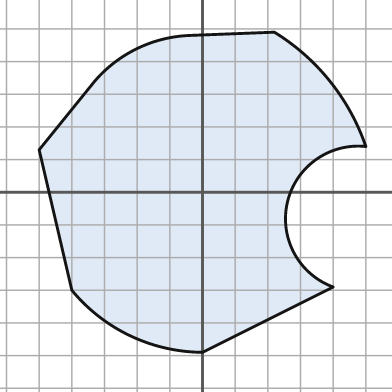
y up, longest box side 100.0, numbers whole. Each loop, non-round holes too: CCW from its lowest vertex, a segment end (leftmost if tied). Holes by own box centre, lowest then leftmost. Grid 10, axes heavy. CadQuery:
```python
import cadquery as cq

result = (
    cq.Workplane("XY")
    .moveTo(0.0, -49.0)
    .lineTo(40.0, -29.0)
    .threePointArc((26.0, -3.0), (50.0, 14.0))
    .threePointArc((39.0, 34.0), (22.0, 49.0))
    .lineTo(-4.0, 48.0)
    .threePointArc((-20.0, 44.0), (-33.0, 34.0))
    .lineTo(-50.0, 13.0)
    .lineTo(-40.0, -30.0)
    .threePointArc((-22.0, -44.0), (0.0, -49.0))
    .close()
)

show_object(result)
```